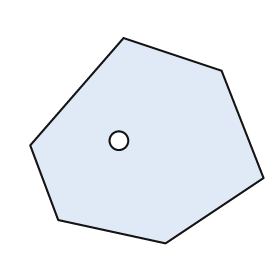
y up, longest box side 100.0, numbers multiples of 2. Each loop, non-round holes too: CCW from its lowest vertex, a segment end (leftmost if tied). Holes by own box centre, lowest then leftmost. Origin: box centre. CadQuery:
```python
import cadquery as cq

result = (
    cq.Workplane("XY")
    .moveTo(8.0, -44.0)
    .lineTo(50.0, -16.0)
    .lineTo(32.0, 30.0)
    .lineTo(-10.0, 44.0)
    .lineTo(-50.0, -2.0)
    .lineTo(-38.0, -34.0)
    .close()
    .moveTo(-12.0, 0.0)
    .circle(4.0)
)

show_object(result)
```